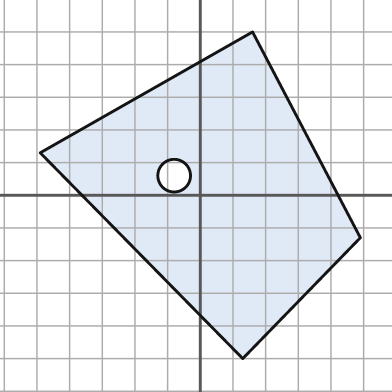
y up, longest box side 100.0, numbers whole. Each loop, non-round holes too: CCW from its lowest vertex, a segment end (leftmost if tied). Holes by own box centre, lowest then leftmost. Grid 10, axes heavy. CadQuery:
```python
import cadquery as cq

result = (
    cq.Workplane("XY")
    .moveTo(13.0, -50.0)
    .lineTo(49.0, -13.0)
    .lineTo(16.0, 50.0)
    .lineTo(-49.0, 13.0)
    .close()
    .moveTo(-8.0, 6.0)
    .circle(5.0)
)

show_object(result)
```